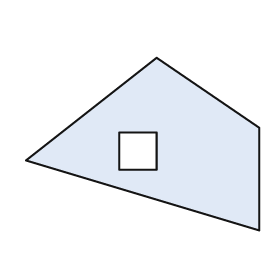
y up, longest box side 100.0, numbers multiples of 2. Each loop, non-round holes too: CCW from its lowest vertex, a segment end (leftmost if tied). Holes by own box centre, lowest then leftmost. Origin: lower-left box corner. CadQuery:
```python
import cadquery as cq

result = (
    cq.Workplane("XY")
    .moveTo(100.0, 0.0)
    .lineTo(100.0, 44.0)
    .lineTo(56.0, 74.0)
    .lineTo(0.0, 30.0)
    .close()
    .moveTo(40.0, 26.0)
    .lineTo(56.0, 26.0)
    .lineTo(56.0, 42.0)
    .lineTo(40.0, 42.0)
    .close()
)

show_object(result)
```